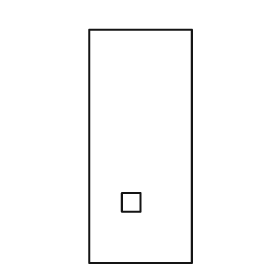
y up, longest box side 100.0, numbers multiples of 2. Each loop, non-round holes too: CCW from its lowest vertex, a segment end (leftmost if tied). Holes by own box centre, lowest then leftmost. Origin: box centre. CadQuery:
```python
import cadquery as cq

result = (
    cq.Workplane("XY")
    .moveTo(-22.0, -50.0)
    .lineTo(22.0, -50.0)
    .lineTo(22.0, 50.0)
    .lineTo(-22.0, 50.0)
    .close()
    .moveTo(-8.0, -28.0)
    .lineTo(0.0, -28.0)
    .lineTo(0.0, -20.0)
    .lineTo(-8.0, -20.0)
    .close()
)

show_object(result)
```